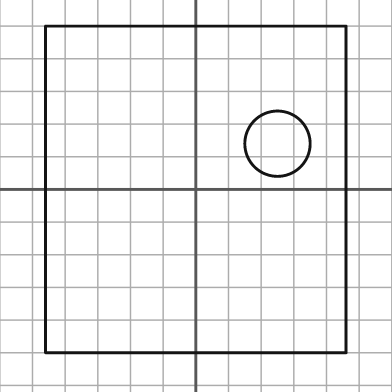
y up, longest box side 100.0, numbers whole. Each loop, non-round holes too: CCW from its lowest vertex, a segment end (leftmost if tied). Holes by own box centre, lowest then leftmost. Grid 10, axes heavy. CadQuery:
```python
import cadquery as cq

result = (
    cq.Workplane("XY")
    .moveTo(-46.0, -50.0)
    .lineTo(46.0, -50.0)
    .lineTo(46.0, 50.0)
    .lineTo(-46.0, 50.0)
    .close()
    .moveTo(25.0, 14.0)
    .circle(10.0)
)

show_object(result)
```